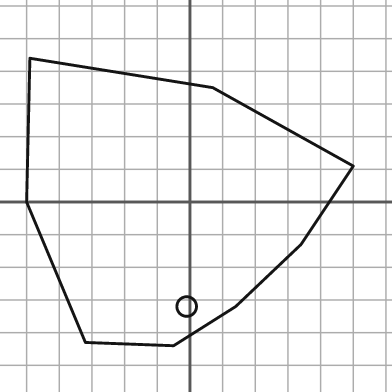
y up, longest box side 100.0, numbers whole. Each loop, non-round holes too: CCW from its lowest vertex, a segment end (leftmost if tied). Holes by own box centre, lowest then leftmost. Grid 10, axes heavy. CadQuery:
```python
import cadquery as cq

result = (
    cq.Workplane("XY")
    .moveTo(-5.0, -44.0)
    .lineTo(14.0, -32.0)
    .lineTo(34.0, -13.0)
    .lineTo(50.0, 11.0)
    .lineTo(7.0, 35.0)
    .lineTo(-49.0, 44.0)
    .lineTo(-50.0, 0.0)
    .lineTo(-32.0, -43.0)
    .close()
    .moveTo(-1.0, -32.0)
    .circle(3.0)
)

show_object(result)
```